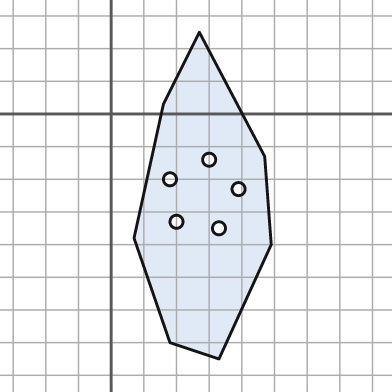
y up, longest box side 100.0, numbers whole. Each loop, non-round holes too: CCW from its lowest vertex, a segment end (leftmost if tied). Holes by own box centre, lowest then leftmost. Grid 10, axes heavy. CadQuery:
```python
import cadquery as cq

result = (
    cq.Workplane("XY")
    .moveTo(33.0, -75.0)
    .lineTo(49.0, -40.0)
    .lineTo(47.0, -13.0)
    .lineTo(27.0, 25.0)
    .lineTo(16.0, 3.0)
    .lineTo(7.0, -38.0)
    .lineTo(18.0, -70.0)
    .close()
    .moveTo(33.0, -35.0)
    .circle(2.0)
    .moveTo(20.0, -33.0)
    .circle(2.0)
    .moveTo(39.0, -23.0)
    .circle(2.0)
    .moveTo(18.0, -20.0)
    .circle(2.0)
    .moveTo(30.0, -14.0)
    .circle(2.0)
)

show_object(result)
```